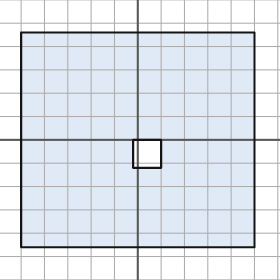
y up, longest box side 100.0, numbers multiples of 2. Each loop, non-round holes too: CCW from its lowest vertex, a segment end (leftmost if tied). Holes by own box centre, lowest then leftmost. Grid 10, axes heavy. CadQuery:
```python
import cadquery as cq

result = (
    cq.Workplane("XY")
    .moveTo(-50.0, -46.0)
    .lineTo(50.0, -46.0)
    .lineTo(50.0, 46.0)
    .lineTo(-50.0, 46.0)
    .close()
    .moveTo(-2.0, -12.0)
    .lineTo(10.0, -12.0)
    .lineTo(10.0, 0.0)
    .lineTo(-2.0, 0.0)
    .close()
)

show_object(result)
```